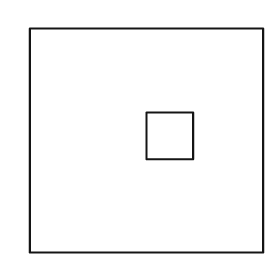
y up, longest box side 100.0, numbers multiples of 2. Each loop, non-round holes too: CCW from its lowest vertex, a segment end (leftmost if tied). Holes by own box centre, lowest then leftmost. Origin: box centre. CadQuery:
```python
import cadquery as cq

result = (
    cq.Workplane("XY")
    .moveTo(-50.0, -48.0)
    .lineTo(50.0, -48.0)
    .lineTo(50.0, 48.0)
    .lineTo(-50.0, 48.0)
    .close()
    .moveTo(0.0, -8.0)
    .lineTo(20.0, -8.0)
    .lineTo(20.0, 12.0)
    .lineTo(0.0, 12.0)
    .close()
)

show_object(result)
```